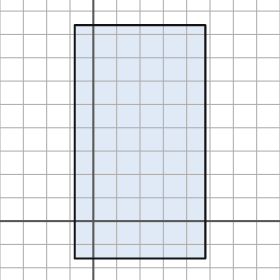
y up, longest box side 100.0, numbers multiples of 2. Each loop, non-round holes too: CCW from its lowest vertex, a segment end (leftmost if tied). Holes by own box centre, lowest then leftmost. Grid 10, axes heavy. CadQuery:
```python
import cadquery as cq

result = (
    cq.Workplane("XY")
    .moveTo(-8.0, -16.0)
    .lineTo(48.0, -16.0)
    .lineTo(48.0, 84.0)
    .lineTo(-8.0, 84.0)
    .close()
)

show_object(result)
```